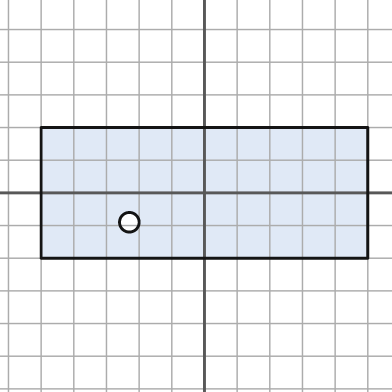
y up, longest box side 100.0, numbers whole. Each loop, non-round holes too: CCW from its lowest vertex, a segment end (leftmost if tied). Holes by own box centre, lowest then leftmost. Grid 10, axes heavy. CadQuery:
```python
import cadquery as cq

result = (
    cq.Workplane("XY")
    .moveTo(-50.0, -20.0)
    .lineTo(50.0, -20.0)
    .lineTo(50.0, 20.0)
    .lineTo(-50.0, 20.0)
    .close()
    .moveTo(-23.0, -9.0)
    .circle(3.0)
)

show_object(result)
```